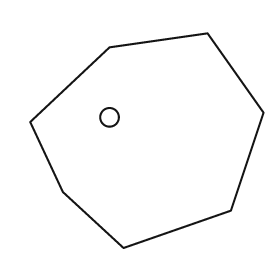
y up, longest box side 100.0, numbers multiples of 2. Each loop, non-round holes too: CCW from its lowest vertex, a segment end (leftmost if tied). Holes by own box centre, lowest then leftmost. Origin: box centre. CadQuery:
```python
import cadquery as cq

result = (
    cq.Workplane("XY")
    .moveTo(-10.0, -46.0)
    .lineTo(36.0, -30.0)
    .lineTo(50.0, 12.0)
    .lineTo(26.0, 46.0)
    .lineTo(-16.0, 40.0)
    .lineTo(-50.0, 8.0)
    .lineTo(-36.0, -22.0)
    .close()
    .moveTo(-16.0, 10.0)
    .circle(4.0)
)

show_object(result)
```